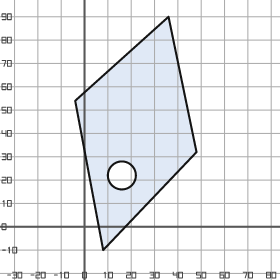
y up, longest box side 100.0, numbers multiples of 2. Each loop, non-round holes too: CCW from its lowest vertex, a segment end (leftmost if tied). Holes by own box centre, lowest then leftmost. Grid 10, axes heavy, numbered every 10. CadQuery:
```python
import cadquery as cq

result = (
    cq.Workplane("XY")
    .moveTo(8.0, -10.0)
    .lineTo(48.0, 32.0)
    .lineTo(36.0, 90.0)
    .lineTo(-4.0, 54.0)
    .close()
    .moveTo(16.0, 22.0)
    .circle(6.0)
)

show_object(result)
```